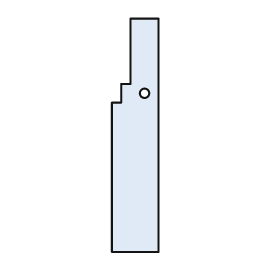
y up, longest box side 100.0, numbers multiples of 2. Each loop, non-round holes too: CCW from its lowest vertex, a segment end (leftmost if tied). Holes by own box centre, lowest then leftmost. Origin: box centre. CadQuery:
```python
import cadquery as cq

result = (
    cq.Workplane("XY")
    .moveTo(-10.0, -50.0)
    .lineTo(10.0, -50.0)
    .lineTo(10.0, 50.0)
    .lineTo(-2.0, 50.0)
    .lineTo(-2.0, 22.0)
    .lineTo(-6.0, 22.0)
    .lineTo(-6.0, 14.0)
    .lineTo(-10.0, 14.0)
    .close()
    .moveTo(4.0, 18.0)
    .circle(2.0)
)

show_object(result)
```